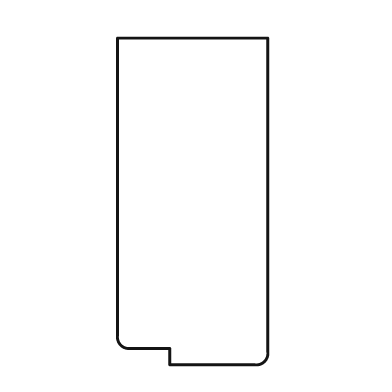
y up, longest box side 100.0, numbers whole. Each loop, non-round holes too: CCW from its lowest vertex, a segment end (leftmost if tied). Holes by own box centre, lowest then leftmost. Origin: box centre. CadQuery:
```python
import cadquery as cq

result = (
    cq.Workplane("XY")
    .moveTo(-7.0, -50.0)
    .lineTo(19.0, -50.0)
    .threePointArc((22.0, -49.0), (23.0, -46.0))
    .lineTo(23.0, 50.0)
    .lineTo(-23.0, 50.0)
    .lineTo(-23.0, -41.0)
    .threePointArc((-22.0, -44.0), (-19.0, -45.0))
    .lineTo(-7.0, -45.0)
    .close()
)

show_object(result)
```